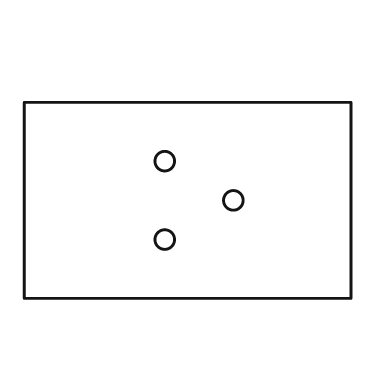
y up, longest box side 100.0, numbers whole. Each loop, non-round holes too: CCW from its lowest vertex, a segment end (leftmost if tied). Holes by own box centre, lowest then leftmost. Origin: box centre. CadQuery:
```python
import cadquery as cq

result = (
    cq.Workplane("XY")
    .moveTo(-50.0, -30.0)
    .lineTo(50.0, -30.0)
    .lineTo(50.0, 30.0)
    .lineTo(-50.0, 30.0)
    .close()
    .moveTo(-7.0, -12.0)
    .circle(3.0)
    .moveTo(14.0, 0.0)
    .circle(3.0)
    .moveTo(-7.0, 12.0)
    .circle(3.0)
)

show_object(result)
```